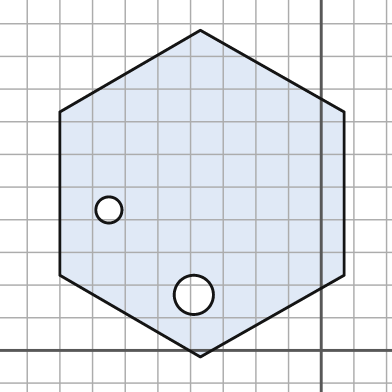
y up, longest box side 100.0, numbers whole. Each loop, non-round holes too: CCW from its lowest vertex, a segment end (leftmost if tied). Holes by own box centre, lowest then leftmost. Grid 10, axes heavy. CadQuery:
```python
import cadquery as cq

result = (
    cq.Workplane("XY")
    .moveTo(-37.0, -2.0)
    .lineTo(7.0, 23.0)
    .lineTo(7.0, 73.0)
    .lineTo(-37.0, 98.0)
    .lineTo(-80.0, 73.0)
    .lineTo(-80.0, 23.0)
    .close()
    .moveTo(-39.0, 17.0)
    .circle(6.0)
    .moveTo(-65.0, 43.0)
    .circle(4.0)
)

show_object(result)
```